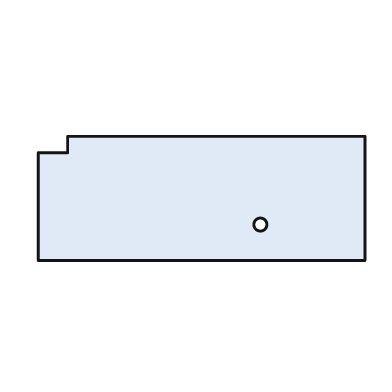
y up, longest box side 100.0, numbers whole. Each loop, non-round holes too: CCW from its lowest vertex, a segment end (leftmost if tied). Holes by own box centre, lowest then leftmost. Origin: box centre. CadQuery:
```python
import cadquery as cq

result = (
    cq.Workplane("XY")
    .moveTo(-50.0, -19.0)
    .lineTo(50.0, -19.0)
    .lineTo(50.0, 19.0)
    .lineTo(-41.0, 19.0)
    .lineTo(-41.0, 14.0)
    .lineTo(-50.0, 14.0)
    .close()
    .moveTo(18.0, -8.0)
    .circle(2.0)
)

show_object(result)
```